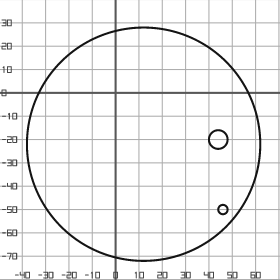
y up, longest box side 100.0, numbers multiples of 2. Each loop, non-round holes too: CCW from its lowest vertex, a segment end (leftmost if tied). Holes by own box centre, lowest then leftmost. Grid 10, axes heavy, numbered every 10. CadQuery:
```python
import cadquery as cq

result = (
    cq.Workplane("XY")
    .moveTo(12.0, -22.0)
    .circle(50.0)
    .moveTo(46.0, -50.0)
    .circle(2.0)
    .moveTo(44.0, -20.0)
    .circle(4.0)
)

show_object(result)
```